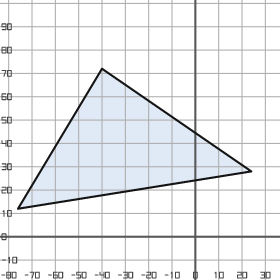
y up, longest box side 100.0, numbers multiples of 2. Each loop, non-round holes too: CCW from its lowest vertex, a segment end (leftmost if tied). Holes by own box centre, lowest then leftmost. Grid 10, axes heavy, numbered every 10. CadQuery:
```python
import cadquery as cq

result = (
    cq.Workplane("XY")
    .moveTo(-76.0, 12.0)
    .lineTo(24.0, 28.0)
    .lineTo(-40.0, 72.0)
    .close()
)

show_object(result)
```